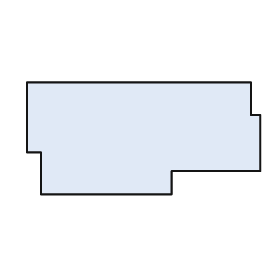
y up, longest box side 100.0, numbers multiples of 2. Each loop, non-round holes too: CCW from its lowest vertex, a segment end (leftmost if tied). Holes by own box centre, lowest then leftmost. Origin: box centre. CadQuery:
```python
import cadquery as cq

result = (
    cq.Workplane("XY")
    .moveTo(-44.0, -24.0)
    .lineTo(12.0, -24.0)
    .lineTo(12.0, -14.0)
    .lineTo(50.0, -14.0)
    .lineTo(50.0, 10.0)
    .lineTo(46.0, 10.0)
    .lineTo(46.0, 24.0)
    .lineTo(-50.0, 24.0)
    .lineTo(-50.0, -6.0)
    .lineTo(-44.0, -6.0)
    .close()
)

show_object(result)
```